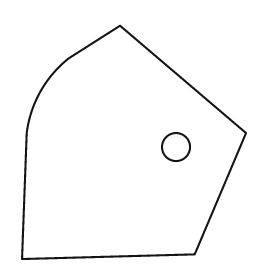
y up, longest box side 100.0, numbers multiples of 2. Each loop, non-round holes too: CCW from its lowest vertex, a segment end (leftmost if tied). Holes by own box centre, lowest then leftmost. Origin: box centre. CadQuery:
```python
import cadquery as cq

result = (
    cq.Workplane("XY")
    .moveTo(-48.0, -50.0)
    .lineTo(26.0, -48.0)
    .lineTo(48.0, 4.0)
    .lineTo(-6.0, 50.0)
    .lineTo(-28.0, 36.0)
    .threePointArc((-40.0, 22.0), (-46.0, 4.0))
    .close()
    .moveTo(18.0, -2.0)
    .circle(6.0)
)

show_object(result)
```